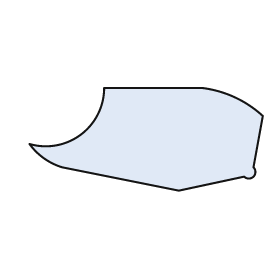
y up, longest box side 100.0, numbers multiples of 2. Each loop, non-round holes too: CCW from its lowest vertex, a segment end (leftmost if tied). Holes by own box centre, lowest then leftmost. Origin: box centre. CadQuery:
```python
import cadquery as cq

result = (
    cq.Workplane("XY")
    .moveTo(14.0, -22.0)
    .lineTo(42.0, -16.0)
    .threePointArc((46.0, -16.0), (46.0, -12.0))
    .lineTo(50.0, 10.0)
    .threePointArc((38.0, 18.0), (24.0, 22.0))
    .lineTo(-18.0, 22.0)
    .threePointArc((-28.0, 2.0), (-50.0, -2.0))
    .threePointArc((-44.0, -8.0), (-36.0, -12.0))
    .close()
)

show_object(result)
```